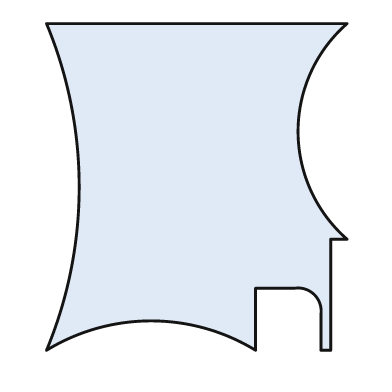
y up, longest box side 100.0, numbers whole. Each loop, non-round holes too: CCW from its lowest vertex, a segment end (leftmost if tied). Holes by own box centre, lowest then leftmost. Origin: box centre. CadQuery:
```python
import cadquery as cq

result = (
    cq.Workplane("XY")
    .moveTo(-46.0, -50.0)
    .threePointArc((-14.0, -41.0), (18.0, -50.0))
    .lineTo(18.0, -31.0)
    .lineTo(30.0, -31.0)
    .threePointArc((36.0, -33.0), (38.0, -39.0))
    .lineTo(38.0, -50.0)
    .lineTo(41.0, -50.0)
    .lineTo(41.0, -16.0)
    .lineTo(46.0, -16.0)
    .threePointArc((31.0, 17.0), (46.0, 50.0))
    .lineTo(-46.0, 50.0)
    .threePointArc((-36.0, 0.0), (-46.0, -50.0))
    .close()
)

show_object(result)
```